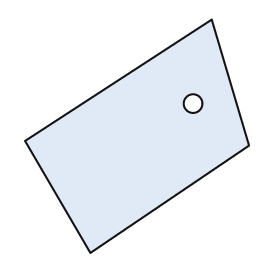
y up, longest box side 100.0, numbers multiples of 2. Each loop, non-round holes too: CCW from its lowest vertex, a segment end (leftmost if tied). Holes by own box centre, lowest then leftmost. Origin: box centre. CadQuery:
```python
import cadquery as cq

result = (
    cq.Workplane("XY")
    .moveTo(-20.0, -50.0)
    .lineTo(48.0, -4.0)
    .lineTo(32.0, 50.0)
    .lineTo(-48.0, -2.0)
    .close()
    .moveTo(24.0, 14.0)
    .circle(4.0)
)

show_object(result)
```